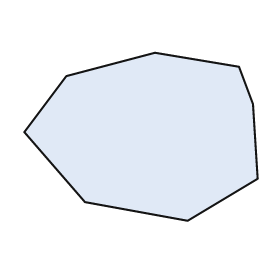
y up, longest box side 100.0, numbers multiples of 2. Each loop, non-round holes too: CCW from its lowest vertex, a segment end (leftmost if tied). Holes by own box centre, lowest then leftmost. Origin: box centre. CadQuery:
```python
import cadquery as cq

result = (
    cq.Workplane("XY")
    .moveTo(20.0, -36.0)
    .lineTo(50.0, -18.0)
    .lineTo(48.0, 14.0)
    .lineTo(42.0, 30.0)
    .lineTo(6.0, 36.0)
    .lineTo(-32.0, 26.0)
    .lineTo(-50.0, 2.0)
    .lineTo(-24.0, -28.0)
    .close()
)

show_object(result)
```